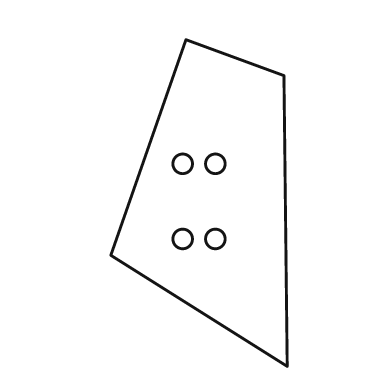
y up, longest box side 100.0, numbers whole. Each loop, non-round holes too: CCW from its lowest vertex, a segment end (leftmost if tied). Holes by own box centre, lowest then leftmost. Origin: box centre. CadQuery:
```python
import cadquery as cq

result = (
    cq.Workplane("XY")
    .moveTo(27.0, -50.0)
    .lineTo(26.0, 39.0)
    .lineTo(-4.0, 50.0)
    .lineTo(-27.0, -16.0)
    .close()
    .moveTo(-5.0, -11.0)
    .circle(3.0)
    .moveTo(5.0, -11.0)
    .circle(3.0)
    .moveTo(-5.0, 12.0)
    .circle(3.0)
    .moveTo(5.0, 12.0)
    .circle(3.0)
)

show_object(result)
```